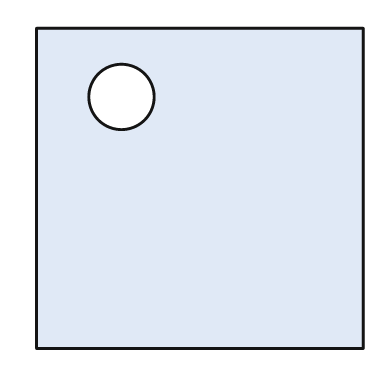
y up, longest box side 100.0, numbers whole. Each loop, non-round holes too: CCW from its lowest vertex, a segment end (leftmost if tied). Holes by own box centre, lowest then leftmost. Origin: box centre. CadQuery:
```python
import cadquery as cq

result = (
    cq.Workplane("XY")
    .moveTo(-50.0, -49.0)
    .lineTo(50.0, -49.0)
    .lineTo(50.0, 49.0)
    .lineTo(-50.0, 49.0)
    .close()
    .moveTo(-24.0, 28.0)
    .circle(10.0)
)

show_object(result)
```